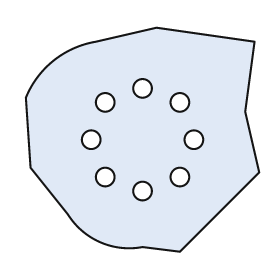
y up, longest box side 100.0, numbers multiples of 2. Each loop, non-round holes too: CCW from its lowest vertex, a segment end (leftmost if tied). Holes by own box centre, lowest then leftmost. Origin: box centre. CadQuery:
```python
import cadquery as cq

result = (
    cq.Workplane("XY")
    .moveTo(16.0, -48.0)
    .lineTo(50.0, -14.0)
    .lineTo(44.0, 12.0)
    .lineTo(48.0, 42.0)
    .lineTo(6.0, 48.0)
    .lineTo(-20.0, 42.0)
    .threePointArc((-38.0, 34.0), (-50.0, 18.0))
    .lineTo(-48.0, -12.0)
    .lineTo(-32.0, -32.0)
    .threePointArc((-18.0, -44.0), (0.0, -46.0))
    .close()
    .moveTo(0.0, -22.0)
    .circle(4.0)
    .moveTo(-16.0, -16.0)
    .circle(4.0)
    .moveTo(16.0, -16.0)
    .circle(4.0)
    .moveTo(-22.0, 0.0)
    .circle(4.0)
    .moveTo(22.0, 0.0)
    .circle(4.0)
    .moveTo(-16.0, 16.0)
    .circle(4.0)
    .moveTo(16.0, 16.0)
    .circle(4.0)
    .moveTo(0.0, 22.0)
    .circle(4.0)
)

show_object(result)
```